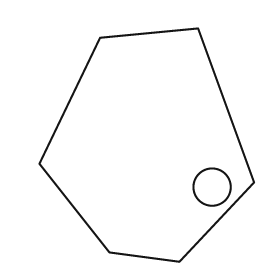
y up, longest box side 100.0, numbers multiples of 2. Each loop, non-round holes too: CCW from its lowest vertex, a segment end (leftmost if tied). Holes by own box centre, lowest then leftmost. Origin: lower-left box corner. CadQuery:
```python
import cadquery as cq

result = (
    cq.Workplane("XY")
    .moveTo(60.0, 0.0)
    .lineTo(92.0, 34.0)
    .lineTo(68.0, 100.0)
    .lineTo(26.0, 96.0)
    .lineTo(0.0, 42.0)
    .lineTo(30.0, 4.0)
    .close()
    .moveTo(74.0, 32.0)
    .circle(8.0)
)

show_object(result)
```